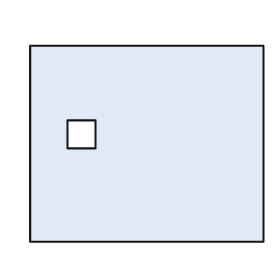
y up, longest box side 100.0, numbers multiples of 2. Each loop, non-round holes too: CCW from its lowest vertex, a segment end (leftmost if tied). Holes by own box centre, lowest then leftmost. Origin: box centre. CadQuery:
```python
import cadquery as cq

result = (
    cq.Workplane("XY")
    .moveTo(-50.0, -42.0)
    .lineTo(50.0, -42.0)
    .lineTo(50.0, 42.0)
    .lineTo(-50.0, 42.0)
    .close()
    .moveTo(-34.0, -2.0)
    .lineTo(-22.0, -2.0)
    .lineTo(-22.0, 10.0)
    .lineTo(-34.0, 10.0)
    .close()
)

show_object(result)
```